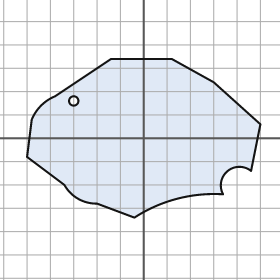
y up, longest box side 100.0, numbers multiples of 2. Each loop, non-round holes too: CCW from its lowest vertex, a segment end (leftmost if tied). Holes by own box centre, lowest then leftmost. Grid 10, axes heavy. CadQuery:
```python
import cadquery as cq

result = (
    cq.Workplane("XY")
    .moveTo(-4.0, -34.0)
    .threePointArc((14.0, -26.0), (34.0, -24.0))
    .threePointArc((36.0, -14.0), (46.0, -14.0))
    .lineTo(50.0, 6.0)
    .lineTo(30.0, 24.0)
    .lineTo(12.0, 34.0)
    .lineTo(-14.0, 34.0)
    .lineTo(-38.0, 18.0)
    .threePointArc((-44.0, 14.0), (-48.0, 8.0))
    .lineTo(-50.0, -8.0)
    .lineTo(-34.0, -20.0)
    .threePointArc((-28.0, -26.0), (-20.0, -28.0))
    .close()
    .moveTo(-30.0, 16.0)
    .circle(2.0)
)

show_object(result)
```